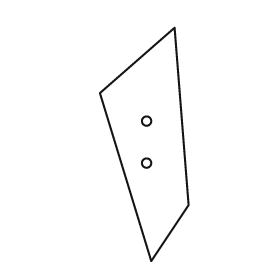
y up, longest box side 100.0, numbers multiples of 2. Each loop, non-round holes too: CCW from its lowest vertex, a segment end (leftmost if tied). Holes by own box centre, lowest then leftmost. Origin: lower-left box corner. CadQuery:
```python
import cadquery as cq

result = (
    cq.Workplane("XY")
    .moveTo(22.0, 0.0)
    .lineTo(38.0, 24.0)
    .lineTo(32.0, 100.0)
    .lineTo(0.0, 72.0)
    .close()
    .moveTo(20.0, 42.0)
    .circle(2.0)
    .moveTo(20.0, 60.0)
    .circle(2.0)
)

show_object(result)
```